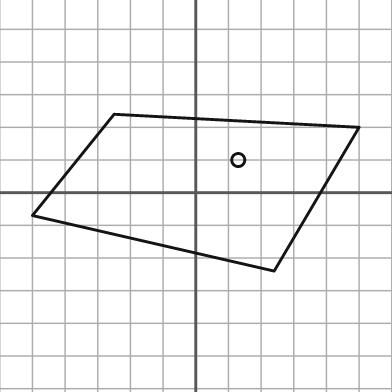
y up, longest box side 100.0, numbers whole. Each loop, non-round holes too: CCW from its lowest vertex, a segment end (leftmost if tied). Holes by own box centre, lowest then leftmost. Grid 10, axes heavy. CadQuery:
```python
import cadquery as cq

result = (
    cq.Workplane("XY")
    .moveTo(24.0, -24.0)
    .lineTo(50.0, 20.0)
    .lineTo(-25.0, 24.0)
    .lineTo(-50.0, -7.0)
    .close()
    .moveTo(13.0, 10.0)
    .circle(2.0)
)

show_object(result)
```